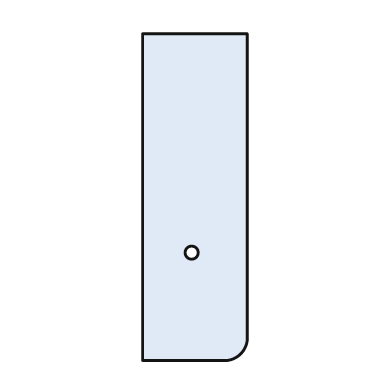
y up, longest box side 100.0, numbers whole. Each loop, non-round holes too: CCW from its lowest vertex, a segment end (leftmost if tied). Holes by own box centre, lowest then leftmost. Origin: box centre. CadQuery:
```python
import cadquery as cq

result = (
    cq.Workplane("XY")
    .moveTo(-16.0, -50.0)
    .lineTo(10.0, -50.0)
    .threePointArc((14.0, -48.0), (16.0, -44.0))
    .lineTo(16.0, 50.0)
    .lineTo(-16.0, 50.0)
    .close()
    .moveTo(-1.0, -17.0)
    .circle(2.0)
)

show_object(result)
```